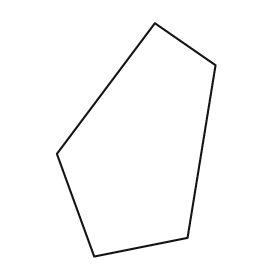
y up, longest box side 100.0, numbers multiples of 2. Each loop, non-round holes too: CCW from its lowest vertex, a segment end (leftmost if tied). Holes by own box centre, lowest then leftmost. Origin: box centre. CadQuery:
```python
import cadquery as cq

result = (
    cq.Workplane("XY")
    .moveTo(-18.0, -50.0)
    .lineTo(22.0, -42.0)
    .lineTo(34.0, 32.0)
    .lineTo(8.0, 50.0)
    .lineTo(-34.0, -6.0)
    .close()
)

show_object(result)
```